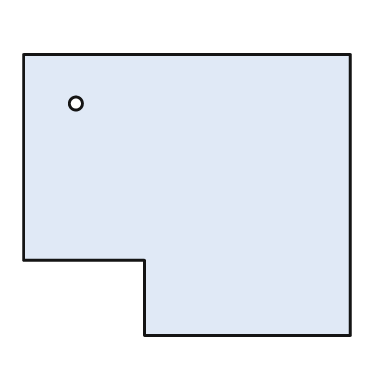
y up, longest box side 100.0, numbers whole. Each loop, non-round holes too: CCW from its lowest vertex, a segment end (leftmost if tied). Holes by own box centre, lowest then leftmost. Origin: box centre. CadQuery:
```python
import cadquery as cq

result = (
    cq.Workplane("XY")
    .moveTo(-13.0, -43.0)
    .lineTo(50.0, -43.0)
    .lineTo(50.0, 43.0)
    .lineTo(-50.0, 43.0)
    .lineTo(-50.0, -20.0)
    .lineTo(-13.0, -20.0)
    .close()
    .moveTo(-34.0, 28.0)
    .circle(2.0)
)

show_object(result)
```